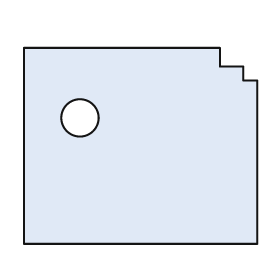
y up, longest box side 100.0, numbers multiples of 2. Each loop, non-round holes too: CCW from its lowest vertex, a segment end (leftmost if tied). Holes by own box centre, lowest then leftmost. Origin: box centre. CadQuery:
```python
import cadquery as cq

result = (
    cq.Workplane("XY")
    .moveTo(-50.0, -42.0)
    .lineTo(50.0, -42.0)
    .lineTo(50.0, 28.0)
    .lineTo(44.0, 28.0)
    .lineTo(44.0, 34.0)
    .lineTo(34.0, 34.0)
    .lineTo(34.0, 42.0)
    .lineTo(-50.0, 42.0)
    .close()
    .moveTo(-26.0, 12.0)
    .circle(8.0)
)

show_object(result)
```